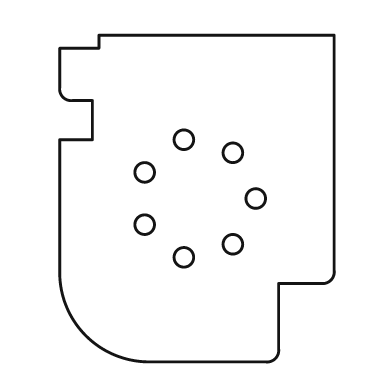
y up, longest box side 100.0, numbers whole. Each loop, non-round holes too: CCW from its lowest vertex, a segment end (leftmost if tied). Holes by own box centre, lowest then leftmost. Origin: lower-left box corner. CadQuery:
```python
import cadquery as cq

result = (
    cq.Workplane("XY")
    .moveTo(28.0, 0.0)
    .lineTo(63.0, 0.0)
    .threePointArc((66.0, 1.0), (67.0, 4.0))
    .lineTo(67.0, 24.0)
    .lineTo(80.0, 24.0)
    .threePointArc((83.0, 25.0), (84.0, 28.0))
    .lineTo(84.0, 100.0)
    .lineTo(12.0, 100.0)
    .lineTo(12.0, 96.0)
    .lineTo(0.0, 96.0)
    .lineTo(0.0, 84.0)
    .threePointArc((1.0, 81.0), (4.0, 80.0))
    .lineTo(10.0, 80.0)
    .lineTo(10.0, 68.0)
    .lineTo(0.0, 68.0)
    .lineTo(0.0, 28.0)
    .threePointArc((8.0, 8.0), (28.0, 0.0))
    .close()
    .moveTo(38.0, 32.0)
    .circle(3.0)
    .moveTo(53.0, 36.0)
    .circle(3.0)
    .moveTo(26.0, 42.0)
    .circle(3.0)
    .moveTo(60.0, 50.0)
    .circle(3.0)
    .moveTo(26.0, 58.0)
    .circle(3.0)
    .moveTo(53.0, 64.0)
    .circle(3.0)
    .moveTo(38.0, 68.0)
    .circle(3.0)
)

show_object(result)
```